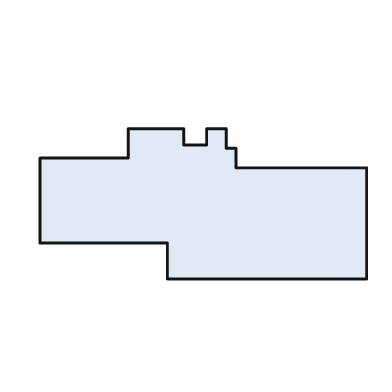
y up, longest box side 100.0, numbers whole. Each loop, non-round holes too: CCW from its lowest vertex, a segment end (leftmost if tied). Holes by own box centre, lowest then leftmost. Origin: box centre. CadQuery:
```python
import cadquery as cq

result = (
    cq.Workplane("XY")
    .moveTo(-11.0, -23.0)
    .lineTo(50.0, -23.0)
    .lineTo(50.0, 11.0)
    .lineTo(10.0, 11.0)
    .lineTo(10.0, 17.0)
    .lineTo(7.0, 17.0)
    .lineTo(7.0, 23.0)
    .lineTo(1.0, 23.0)
    .lineTo(1.0, 18.0)
    .lineTo(-6.0, 18.0)
    .lineTo(-6.0, 23.0)
    .lineTo(-23.0, 23.0)
    .lineTo(-23.0, 14.0)
    .lineTo(-50.0, 14.0)
    .lineTo(-50.0, -12.0)
    .lineTo(-11.0, -12.0)
    .close()
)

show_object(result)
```